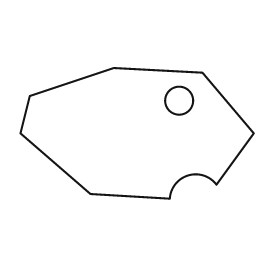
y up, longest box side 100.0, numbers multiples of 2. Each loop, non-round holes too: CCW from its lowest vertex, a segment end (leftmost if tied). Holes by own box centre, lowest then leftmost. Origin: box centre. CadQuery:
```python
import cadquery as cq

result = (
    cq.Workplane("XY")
    .moveTo(14.0, -28.0)
    .threePointArc((22.0, -18.0), (34.0, -22.0))
    .lineTo(50.0, 0.0)
    .lineTo(28.0, 26.0)
    .lineTo(-10.0, 28.0)
    .lineTo(-46.0, 16.0)
    .lineTo(-50.0, 0.0)
    .lineTo(-20.0, -26.0)
    .close()
    .moveTo(18.0, 14.0)
    .circle(6.0)
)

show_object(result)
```